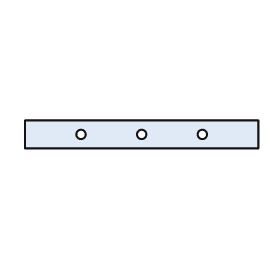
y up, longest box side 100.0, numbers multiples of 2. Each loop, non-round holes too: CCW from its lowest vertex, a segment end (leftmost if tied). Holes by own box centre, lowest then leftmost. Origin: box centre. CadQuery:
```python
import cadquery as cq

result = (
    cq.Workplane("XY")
    .moveTo(-50.0, -6.0)
    .lineTo(50.0, -6.0)
    .lineTo(50.0, 6.0)
    .lineTo(-50.0, 6.0)
    .close()
    .moveTo(-26.0, 0.0)
    .circle(2.0)
    .moveTo(0.0, 0.0)
    .circle(2.0)
    .moveTo(26.0, 0.0)
    .circle(2.0)
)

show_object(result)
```